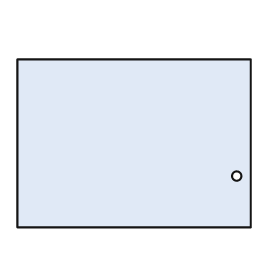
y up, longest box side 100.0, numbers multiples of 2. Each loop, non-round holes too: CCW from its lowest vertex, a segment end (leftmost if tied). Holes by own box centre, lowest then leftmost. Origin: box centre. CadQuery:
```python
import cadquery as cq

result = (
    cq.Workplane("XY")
    .moveTo(-50.0, -36.0)
    .lineTo(50.0, -36.0)
    .lineTo(50.0, 36.0)
    .lineTo(-50.0, 36.0)
    .close()
    .moveTo(44.0, -14.0)
    .circle(2.0)
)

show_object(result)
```